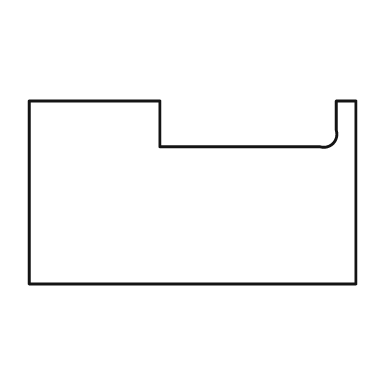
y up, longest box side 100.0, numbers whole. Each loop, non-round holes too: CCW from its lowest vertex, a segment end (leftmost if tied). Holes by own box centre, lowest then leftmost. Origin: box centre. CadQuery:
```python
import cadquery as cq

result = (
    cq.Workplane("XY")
    .moveTo(-50.0, -28.0)
    .lineTo(50.0, -28.0)
    .lineTo(50.0, 28.0)
    .lineTo(44.0, 28.0)
    .lineTo(44.0, 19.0)
    .threePointArc((43.0, 15.0), (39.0, 14.0))
    .lineTo(-10.0, 14.0)
    .lineTo(-10.0, 28.0)
    .lineTo(-50.0, 28.0)
    .close()
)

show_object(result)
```